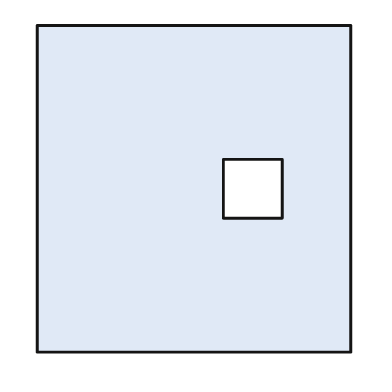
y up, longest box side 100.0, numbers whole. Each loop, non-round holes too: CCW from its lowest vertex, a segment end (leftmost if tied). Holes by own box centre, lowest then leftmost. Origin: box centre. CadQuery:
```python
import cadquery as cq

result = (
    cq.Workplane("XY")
    .moveTo(-48.0, -50.0)
    .lineTo(48.0, -50.0)
    .lineTo(48.0, 50.0)
    .lineTo(-48.0, 50.0)
    .close()
    .moveTo(9.0, -9.0)
    .lineTo(27.0, -9.0)
    .lineTo(27.0, 9.0)
    .lineTo(9.0, 9.0)
    .close()
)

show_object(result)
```